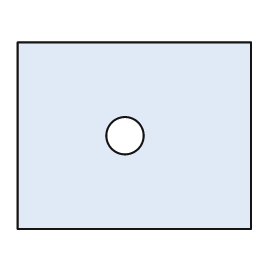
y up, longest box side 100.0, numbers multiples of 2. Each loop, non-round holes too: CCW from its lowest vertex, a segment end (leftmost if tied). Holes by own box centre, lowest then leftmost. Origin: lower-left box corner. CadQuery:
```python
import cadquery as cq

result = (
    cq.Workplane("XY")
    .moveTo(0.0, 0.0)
    .lineTo(100.0, 0.0)
    .lineTo(100.0, 80.0)
    .lineTo(0.0, 80.0)
    .close()
    .moveTo(46.0, 40.0)
    .circle(8.0)
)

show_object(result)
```